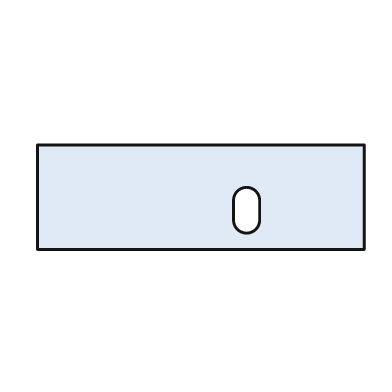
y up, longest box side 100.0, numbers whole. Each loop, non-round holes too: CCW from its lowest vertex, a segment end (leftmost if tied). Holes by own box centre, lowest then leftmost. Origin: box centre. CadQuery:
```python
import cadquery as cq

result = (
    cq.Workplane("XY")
    .moveTo(-50.0, -16.0)
    .lineTo(50.0, -16.0)
    .lineTo(50.0, 16.0)
    .lineTo(-50.0, 16.0)
    .close()
    .moveTo(10.0, -7.0)
    .threePointArc((14.0, -11.0), (18.0, -7.0))
    .lineTo(18.0, -1.0)
    .threePointArc((14.0, 3.0), (10.0, -1.0))
    .close()
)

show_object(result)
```